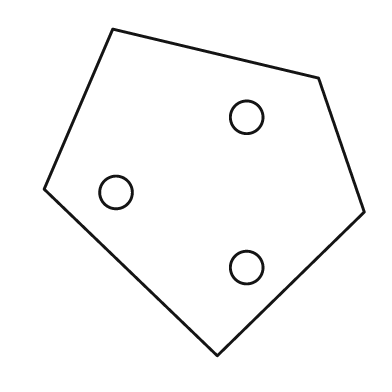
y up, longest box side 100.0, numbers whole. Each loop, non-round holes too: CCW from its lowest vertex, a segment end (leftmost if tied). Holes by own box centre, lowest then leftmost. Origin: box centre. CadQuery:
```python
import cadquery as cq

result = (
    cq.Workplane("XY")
    .moveTo(4.0, -50.0)
    .lineTo(49.0, -6.0)
    .lineTo(35.0, 35.0)
    .lineTo(-28.0, 50.0)
    .lineTo(-49.0, 1.0)
    .close()
    .moveTo(13.0, -23.0)
    .circle(5.0)
    .moveTo(-27.0, 0.0)
    .circle(5.0)
    .moveTo(13.0, 23.0)
    .circle(5.0)
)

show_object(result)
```